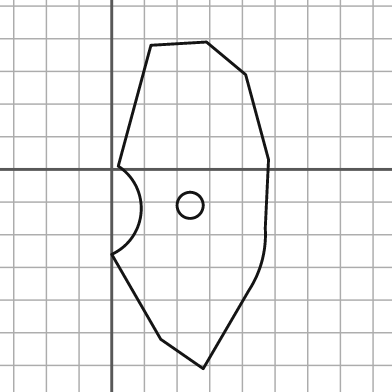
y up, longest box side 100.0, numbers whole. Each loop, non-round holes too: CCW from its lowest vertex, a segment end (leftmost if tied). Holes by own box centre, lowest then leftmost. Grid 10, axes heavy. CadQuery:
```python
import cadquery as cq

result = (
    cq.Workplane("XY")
    .moveTo(28.0, -61.0)
    .lineTo(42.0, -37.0)
    .threePointArc((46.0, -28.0), (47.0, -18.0))
    .lineTo(48.0, 3.0)
    .lineTo(41.0, 29.0)
    .lineTo(29.0, 39.0)
    .lineTo(12.0, 38.0)
    .lineTo(2.0, 1.0)
    .threePointArc((9.0, -13.0), (0.0, -26.0))
    .lineTo(15.0, -52.0)
    .close()
    .moveTo(24.0, -11.0)
    .circle(4.0)
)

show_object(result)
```